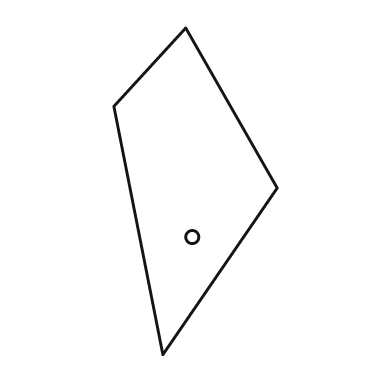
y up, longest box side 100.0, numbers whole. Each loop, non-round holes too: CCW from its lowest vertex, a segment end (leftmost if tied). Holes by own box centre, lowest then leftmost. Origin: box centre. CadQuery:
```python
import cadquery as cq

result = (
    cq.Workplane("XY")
    .moveTo(-10.0, -50.0)
    .lineTo(25.0, 1.0)
    .lineTo(-3.0, 50.0)
    .lineTo(-25.0, 26.0)
    .close()
    .moveTo(-1.0, -14.0)
    .circle(2.0)
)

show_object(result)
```